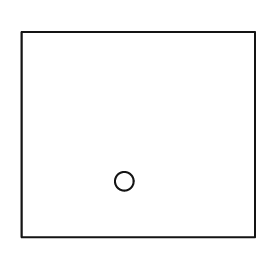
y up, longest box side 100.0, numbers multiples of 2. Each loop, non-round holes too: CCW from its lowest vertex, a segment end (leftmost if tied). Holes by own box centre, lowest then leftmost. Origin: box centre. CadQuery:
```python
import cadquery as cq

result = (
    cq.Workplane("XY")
    .moveTo(-50.0, -44.0)
    .lineTo(50.0, -44.0)
    .lineTo(50.0, 44.0)
    .lineTo(-50.0, 44.0)
    .close()
    .moveTo(-6.0, -20.0)
    .circle(4.0)
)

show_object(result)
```